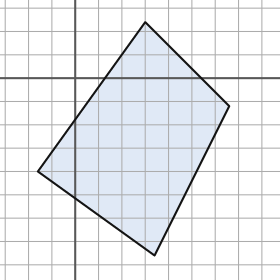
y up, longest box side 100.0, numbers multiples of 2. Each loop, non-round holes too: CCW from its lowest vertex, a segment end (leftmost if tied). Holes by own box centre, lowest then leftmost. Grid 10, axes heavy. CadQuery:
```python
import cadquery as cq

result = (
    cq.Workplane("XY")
    .moveTo(34.0, -76.0)
    .lineTo(66.0, -12.0)
    .lineTo(30.0, 24.0)
    .lineTo(-16.0, -40.0)
    .close()
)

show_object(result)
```